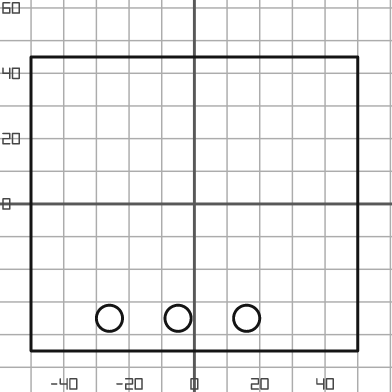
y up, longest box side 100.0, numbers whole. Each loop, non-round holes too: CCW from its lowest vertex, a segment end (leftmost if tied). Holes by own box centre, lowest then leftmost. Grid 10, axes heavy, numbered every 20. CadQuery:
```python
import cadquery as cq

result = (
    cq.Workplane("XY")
    .moveTo(-50.0, -45.0)
    .lineTo(50.0, -45.0)
    .lineTo(50.0, 45.0)
    .lineTo(-50.0, 45.0)
    .close()
    .moveTo(-26.0, -35.0)
    .circle(4.0)
    .moveTo(-5.0, -35.0)
    .circle(4.0)
    .moveTo(16.0, -35.0)
    .circle(4.0)
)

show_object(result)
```